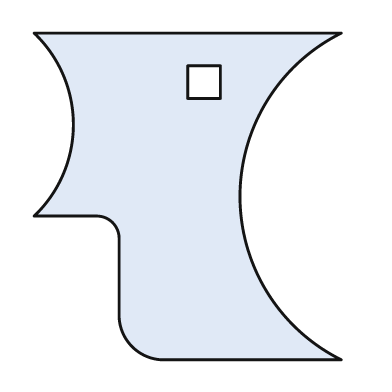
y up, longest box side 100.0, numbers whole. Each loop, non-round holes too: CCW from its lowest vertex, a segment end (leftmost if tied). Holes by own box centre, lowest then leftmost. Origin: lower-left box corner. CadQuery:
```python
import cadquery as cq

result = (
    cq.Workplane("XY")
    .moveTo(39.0, 0.0)
    .lineTo(94.0, 0.0)
    .threePointArc((63.0, 50.0), (94.0, 100.0))
    .lineTo(0.0, 100.0)
    .threePointArc((12.0, 72.0), (0.0, 44.0))
    .lineTo(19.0, 44.0)
    .threePointArc((24.0, 42.0), (26.0, 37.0))
    .lineTo(26.0, 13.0)
    .threePointArc((30.0, 4.0), (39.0, 0.0))
    .close()
    .moveTo(47.0, 80.0)
    .lineTo(57.0, 80.0)
    .lineTo(57.0, 90.0)
    .lineTo(47.0, 90.0)
    .close()
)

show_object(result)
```